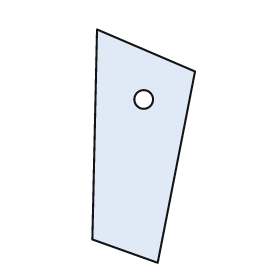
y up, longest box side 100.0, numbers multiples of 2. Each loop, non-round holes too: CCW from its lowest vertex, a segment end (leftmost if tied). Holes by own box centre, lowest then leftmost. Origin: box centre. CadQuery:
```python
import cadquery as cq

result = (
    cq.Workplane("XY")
    .moveTo(6.0, -50.0)
    .lineTo(22.0, 32.0)
    .lineTo(-20.0, 50.0)
    .lineTo(-22.0, -40.0)
    .close()
    .moveTo(0.0, 20.0)
    .circle(4.0)
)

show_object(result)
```